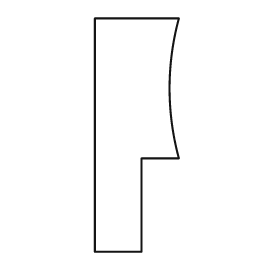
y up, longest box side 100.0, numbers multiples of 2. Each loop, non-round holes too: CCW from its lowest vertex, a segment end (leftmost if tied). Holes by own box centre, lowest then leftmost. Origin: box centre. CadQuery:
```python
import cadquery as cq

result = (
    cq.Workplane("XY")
    .moveTo(-18.0, -50.0)
    .lineTo(2.0, -50.0)
    .lineTo(2.0, -10.0)
    .lineTo(18.0, -10.0)
    .threePointArc((14.0, 20.0), (18.0, 50.0))
    .lineTo(-18.0, 50.0)
    .close()
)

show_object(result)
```